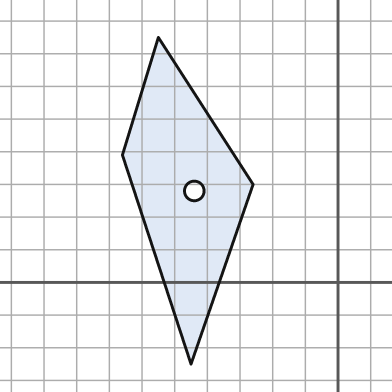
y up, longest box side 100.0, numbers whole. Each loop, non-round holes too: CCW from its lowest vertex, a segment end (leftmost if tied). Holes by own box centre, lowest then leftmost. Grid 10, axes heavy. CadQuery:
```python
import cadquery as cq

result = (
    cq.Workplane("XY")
    .moveTo(-45.0, -25.0)
    .lineTo(-26.0, 30.0)
    .lineTo(-55.0, 75.0)
    .lineTo(-66.0, 39.0)
    .close()
    .moveTo(-44.0, 28.0)
    .circle(3.0)
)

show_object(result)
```